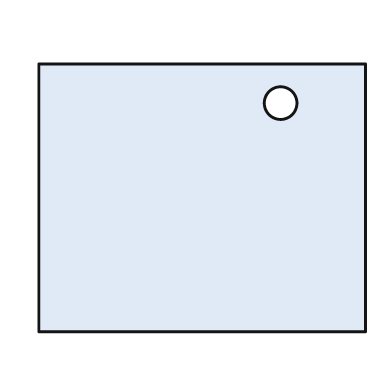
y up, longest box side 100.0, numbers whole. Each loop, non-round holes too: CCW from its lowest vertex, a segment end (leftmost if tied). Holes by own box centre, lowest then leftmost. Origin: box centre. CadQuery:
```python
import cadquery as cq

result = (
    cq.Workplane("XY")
    .moveTo(-50.0, -41.0)
    .lineTo(50.0, -41.0)
    .lineTo(50.0, 41.0)
    .lineTo(-50.0, 41.0)
    .close()
    .moveTo(24.0, 29.0)
    .circle(5.0)
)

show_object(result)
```